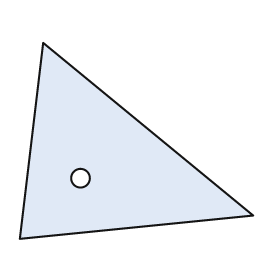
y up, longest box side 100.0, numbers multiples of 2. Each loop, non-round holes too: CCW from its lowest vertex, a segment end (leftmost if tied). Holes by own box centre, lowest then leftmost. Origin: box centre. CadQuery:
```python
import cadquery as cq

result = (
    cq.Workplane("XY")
    .moveTo(-50.0, -42.0)
    .lineTo(50.0, -32.0)
    .lineTo(-40.0, 42.0)
    .close()
    .moveTo(-24.0, -16.0)
    .circle(4.0)
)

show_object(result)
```